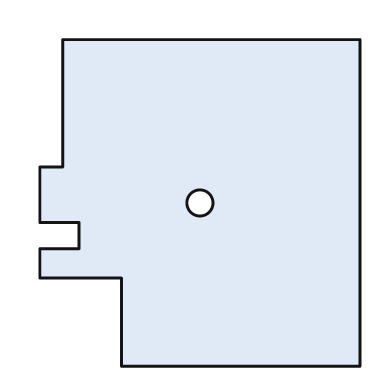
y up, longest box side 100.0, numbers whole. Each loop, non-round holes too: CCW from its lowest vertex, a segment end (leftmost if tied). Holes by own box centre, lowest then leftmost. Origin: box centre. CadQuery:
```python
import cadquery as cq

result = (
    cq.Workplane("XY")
    .moveTo(-24.0, -50.0)
    .lineTo(49.0, -50.0)
    .lineTo(49.0, 50.0)
    .lineTo(-42.0, 50.0)
    .lineTo(-42.0, 11.0)
    .lineTo(-49.0, 11.0)
    .lineTo(-49.0, -6.0)
    .lineTo(-37.0, -6.0)
    .lineTo(-37.0, -14.0)
    .lineTo(-49.0, -14.0)
    .lineTo(-49.0, -23.0)
    .lineTo(-24.0, -23.0)
    .close()
    .moveTo(0.0, 0.0)
    .circle(4.0)
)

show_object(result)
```